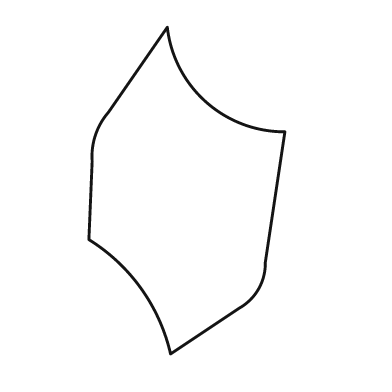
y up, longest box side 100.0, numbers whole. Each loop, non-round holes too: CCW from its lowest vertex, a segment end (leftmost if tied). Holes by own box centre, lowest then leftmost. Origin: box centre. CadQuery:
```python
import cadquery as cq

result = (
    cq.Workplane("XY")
    .moveTo(-5.0, -50.0)
    .lineTo(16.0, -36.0)
    .threePointArc((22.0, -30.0), (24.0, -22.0))
    .lineTo(30.0, 18.0)
    .threePointArc((6.0, 27.0), (-6.0, 50.0))
    .lineTo(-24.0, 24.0)
    .threePointArc((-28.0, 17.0), (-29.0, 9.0))
    .lineTo(-30.0, -15.0)
    .threePointArc((-14.0, -30.0), (-5.0, -50.0))
    .close()
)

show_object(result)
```